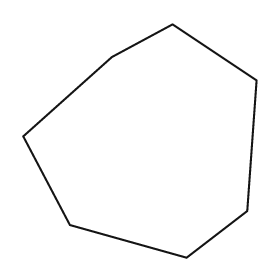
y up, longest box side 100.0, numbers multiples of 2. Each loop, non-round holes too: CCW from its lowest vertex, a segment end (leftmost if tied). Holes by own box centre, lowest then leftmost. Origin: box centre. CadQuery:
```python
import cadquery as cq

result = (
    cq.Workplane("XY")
    .moveTo(20.0, -50.0)
    .lineTo(46.0, -30.0)
    .lineTo(50.0, 26.0)
    .lineTo(14.0, 50.0)
    .lineTo(-12.0, 36.0)
    .lineTo(-50.0, 2.0)
    .lineTo(-30.0, -36.0)
    .close()
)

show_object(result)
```